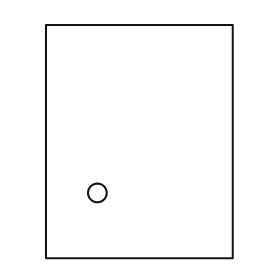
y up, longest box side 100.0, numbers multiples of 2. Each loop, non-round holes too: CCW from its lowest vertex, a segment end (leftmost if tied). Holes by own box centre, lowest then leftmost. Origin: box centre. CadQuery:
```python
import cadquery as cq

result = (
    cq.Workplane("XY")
    .moveTo(-40.0, -50.0)
    .lineTo(40.0, -50.0)
    .lineTo(40.0, 50.0)
    .lineTo(-40.0, 50.0)
    .close()
    .moveTo(-18.0, -22.0)
    .circle(4.0)
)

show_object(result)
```